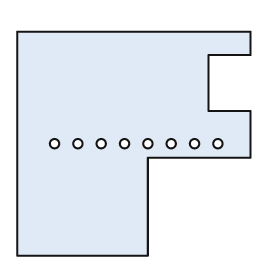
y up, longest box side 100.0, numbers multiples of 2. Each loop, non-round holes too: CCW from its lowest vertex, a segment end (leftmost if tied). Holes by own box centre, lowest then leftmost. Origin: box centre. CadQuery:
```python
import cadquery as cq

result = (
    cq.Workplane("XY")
    .moveTo(-50.0, -48.0)
    .lineTo(6.0, -48.0)
    .lineTo(6.0, -6.0)
    .lineTo(50.0, -6.0)
    .lineTo(50.0, 14.0)
    .lineTo(32.0, 14.0)
    .lineTo(32.0, 38.0)
    .lineTo(50.0, 38.0)
    .lineTo(50.0, 48.0)
    .lineTo(-50.0, 48.0)
    .close()
    .moveTo(-34.0, 0.0)
    .circle(2.0)
    .moveTo(-24.0, 0.0)
    .circle(2.0)
    .moveTo(-14.0, 0.0)
    .circle(2.0)
    .moveTo(-4.0, 0.0)
    .circle(2.0)
    .moveTo(6.0, 0.0)
    .circle(2.0)
    .moveTo(16.0, 0.0)
    .circle(2.0)
    .moveTo(26.0, 0.0)
    .circle(2.0)
    .moveTo(36.0, 0.0)
    .circle(2.0)
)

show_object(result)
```